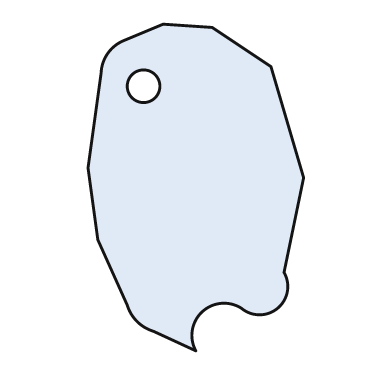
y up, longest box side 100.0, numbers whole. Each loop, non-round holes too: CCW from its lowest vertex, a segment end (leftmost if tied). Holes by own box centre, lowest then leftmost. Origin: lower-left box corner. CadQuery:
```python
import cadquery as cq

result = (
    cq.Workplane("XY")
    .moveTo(33.0, 0.0)
    .threePointArc((35.0, 12.0), (47.0, 13.0))
    .threePointArc((58.0, 13.0), (60.0, 24.0))
    .lineTo(66.0, 53.0)
    .lineTo(56.0, 87.0)
    .lineTo(38.0, 99.0)
    .lineTo(23.0, 100.0)
    .lineTo(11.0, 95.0)
    .threePointArc((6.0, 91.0), (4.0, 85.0))
    .lineTo(0.0, 56.0)
    .lineTo(3.0, 34.0)
    .lineTo(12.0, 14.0)
    .threePointArc((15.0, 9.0), (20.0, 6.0))
    .close()
    .moveTo(17.0, 81.0)
    .circle(5.0)
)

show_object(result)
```